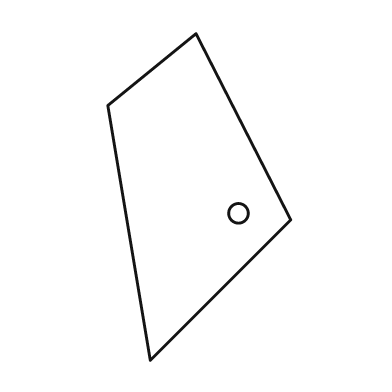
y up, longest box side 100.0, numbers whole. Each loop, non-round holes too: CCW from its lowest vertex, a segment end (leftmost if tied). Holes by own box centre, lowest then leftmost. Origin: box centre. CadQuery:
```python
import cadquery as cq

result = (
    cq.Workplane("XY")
    .moveTo(-15.0, -50.0)
    .lineTo(28.0, -7.0)
    .lineTo(-1.0, 50.0)
    .lineTo(-28.0, 28.0)
    .close()
    .moveTo(12.0, -5.0)
    .circle(3.0)
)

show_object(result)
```